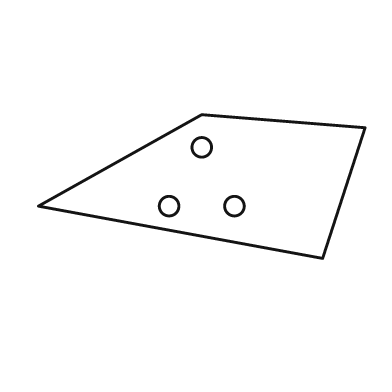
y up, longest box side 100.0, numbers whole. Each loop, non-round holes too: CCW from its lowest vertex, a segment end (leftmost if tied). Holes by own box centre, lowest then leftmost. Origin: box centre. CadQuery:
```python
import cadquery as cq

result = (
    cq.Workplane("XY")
    .moveTo(37.0, -22.0)
    .lineTo(50.0, 18.0)
    .lineTo(0.0, 22.0)
    .lineTo(-50.0, -6.0)
    .close()
    .moveTo(-10.0, -6.0)
    .circle(3.0)
    .moveTo(10.0, -6.0)
    .circle(3.0)
    .moveTo(0.0, 12.0)
    .circle(3.0)
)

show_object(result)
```